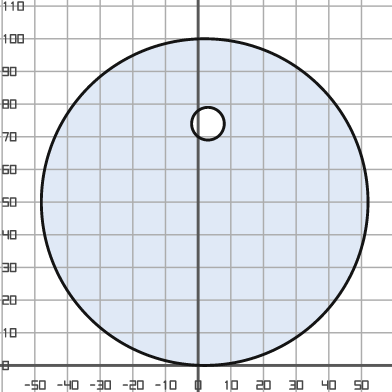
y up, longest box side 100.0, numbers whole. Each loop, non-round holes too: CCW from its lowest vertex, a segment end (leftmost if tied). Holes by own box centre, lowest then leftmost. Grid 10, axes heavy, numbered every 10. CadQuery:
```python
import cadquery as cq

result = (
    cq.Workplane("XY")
    .moveTo(2.0, 50.0)
    .circle(50.0)
    .moveTo(3.0, 74.0)
    .circle(5.0)
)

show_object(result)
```